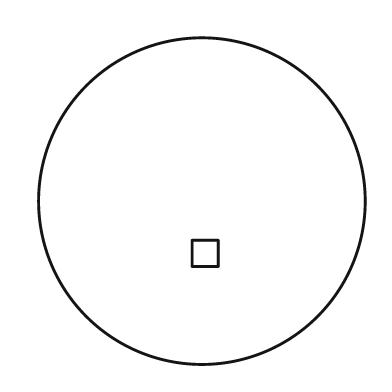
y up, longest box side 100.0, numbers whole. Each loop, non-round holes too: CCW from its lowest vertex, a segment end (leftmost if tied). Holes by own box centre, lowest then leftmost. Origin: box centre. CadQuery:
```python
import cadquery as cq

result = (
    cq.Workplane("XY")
    .moveTo(0.0, 0.0)
    .circle(50.0)
    .moveTo(-3.0, -20.0)
    .lineTo(5.0, -20.0)
    .lineTo(5.0, -12.0)
    .lineTo(-3.0, -12.0)
    .close()
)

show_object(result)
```